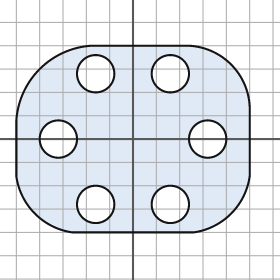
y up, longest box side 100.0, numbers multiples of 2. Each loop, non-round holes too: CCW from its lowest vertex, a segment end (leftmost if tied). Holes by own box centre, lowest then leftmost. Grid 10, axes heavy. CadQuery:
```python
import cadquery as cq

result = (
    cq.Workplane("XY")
    .moveTo(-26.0, -40.0)
    .lineTo(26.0, -40.0)
    .threePointArc((42.0, -32.0), (50.0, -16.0))
    .lineTo(50.0, 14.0)
    .threePointArc((42.0, 32.0), (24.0, 40.0))
    .lineTo(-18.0, 40.0)
    .threePointArc((-40.0, 30.0), (-50.0, 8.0))
    .lineTo(-50.0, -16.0)
    .threePointArc((-42.0, -32.0), (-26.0, -40.0))
    .close()
    .moveTo(-16.0, -28.0)
    .circle(8.0)
    .moveTo(16.0, -28.0)
    .circle(8.0)
    .moveTo(-32.0, 0.0)
    .circle(8.0)
    .moveTo(32.0, 0.0)
    .circle(8.0)
    .moveTo(-16.0, 28.0)
    .circle(8.0)
    .moveTo(16.0, 28.0)
    .circle(8.0)
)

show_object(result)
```